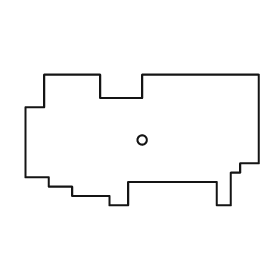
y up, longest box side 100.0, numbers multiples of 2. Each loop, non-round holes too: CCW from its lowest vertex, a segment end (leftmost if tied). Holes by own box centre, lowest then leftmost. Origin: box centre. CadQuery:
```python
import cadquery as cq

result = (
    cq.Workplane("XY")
    .moveTo(-14.0, -28.0)
    .lineTo(-6.0, -28.0)
    .lineTo(-6.0, -18.0)
    .lineTo(32.0, -18.0)
    .lineTo(32.0, -28.0)
    .lineTo(38.0, -28.0)
    .lineTo(38.0, -14.0)
    .lineTo(42.0, -14.0)
    .lineTo(42.0, -10.0)
    .lineTo(50.0, -10.0)
    .lineTo(50.0, 28.0)
    .lineTo(0.0, 28.0)
    .lineTo(0.0, 18.0)
    .lineTo(-18.0, 18.0)
    .lineTo(-18.0, 28.0)
    .lineTo(-42.0, 28.0)
    .lineTo(-42.0, 14.0)
    .lineTo(-50.0, 14.0)
    .lineTo(-50.0, -16.0)
    .lineTo(-40.0, -16.0)
    .lineTo(-40.0, -20.0)
    .lineTo(-30.0, -20.0)
    .lineTo(-30.0, -24.0)
    .lineTo(-14.0, -24.0)
    .close()
    .moveTo(0.0, 0.0)
    .circle(2.0)
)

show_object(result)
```